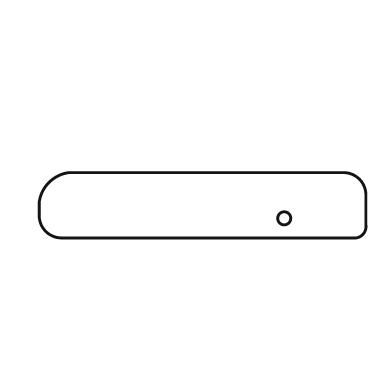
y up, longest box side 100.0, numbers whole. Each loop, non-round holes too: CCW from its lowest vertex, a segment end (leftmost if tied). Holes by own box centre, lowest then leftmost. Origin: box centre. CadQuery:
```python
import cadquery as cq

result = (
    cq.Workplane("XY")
    .moveTo(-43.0, -10.0)
    .lineTo(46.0, -10.0)
    .threePointArc((49.0, -9.0), (50.0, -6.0))
    .lineTo(50.0, 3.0)
    .threePointArc((48.0, 8.0), (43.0, 10.0))
    .lineTo(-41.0, 10.0)
    .threePointArc((-47.0, 7.0), (-50.0, 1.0))
    .lineTo(-50.0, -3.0)
    .threePointArc((-48.0, -8.0), (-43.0, -10.0))
    .close()
    .moveTo(25.0, -4.0)
    .circle(2.0)
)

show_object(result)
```